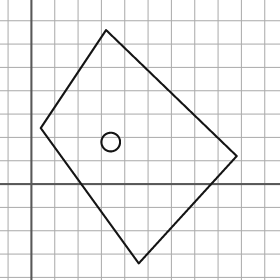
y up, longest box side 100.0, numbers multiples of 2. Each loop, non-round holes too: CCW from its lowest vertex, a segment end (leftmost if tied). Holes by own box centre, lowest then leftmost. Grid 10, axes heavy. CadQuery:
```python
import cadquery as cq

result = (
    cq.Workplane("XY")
    .moveTo(46.0, -34.0)
    .lineTo(88.0, 12.0)
    .lineTo(32.0, 66.0)
    .lineTo(4.0, 24.0)
    .close()
    .moveTo(34.0, 18.0)
    .circle(4.0)
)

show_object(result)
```